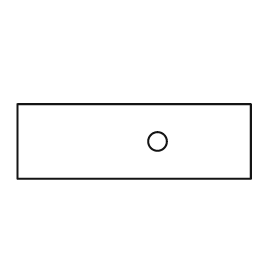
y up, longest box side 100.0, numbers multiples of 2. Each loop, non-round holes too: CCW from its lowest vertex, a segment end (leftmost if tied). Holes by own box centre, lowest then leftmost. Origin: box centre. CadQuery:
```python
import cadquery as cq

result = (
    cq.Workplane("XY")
    .moveTo(-50.0, -16.0)
    .lineTo(50.0, -16.0)
    .lineTo(50.0, 16.0)
    .lineTo(-50.0, 16.0)
    .close()
    .moveTo(10.0, 0.0)
    .circle(4.0)
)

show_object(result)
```